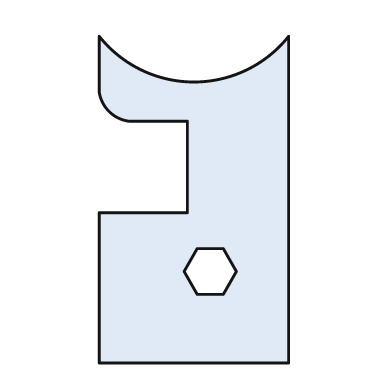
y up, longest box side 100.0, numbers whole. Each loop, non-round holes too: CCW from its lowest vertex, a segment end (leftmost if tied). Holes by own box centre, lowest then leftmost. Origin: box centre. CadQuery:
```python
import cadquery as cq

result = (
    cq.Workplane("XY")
    .moveTo(-29.0, -50.0)
    .lineTo(29.0, -50.0)
    .lineTo(29.0, 50.0)
    .threePointArc((0.0, 36.0), (-29.0, 50.0))
    .lineTo(-29.0, 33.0)
    .threePointArc((-26.0, 27.0), (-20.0, 24.0))
    .lineTo(-2.0, 24.0)
    .lineTo(-2.0, -4.0)
    .lineTo(-29.0, -4.0)
    .close()
    .moveTo(1.0, -29.0)
    .lineTo(9.0, -29.0)
    .lineTo(13.0, -22.0)
    .lineTo(9.0, -15.0)
    .lineTo(1.0, -15.0)
    .lineTo(-3.0, -22.0)
    .close()
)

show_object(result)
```